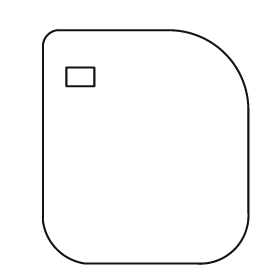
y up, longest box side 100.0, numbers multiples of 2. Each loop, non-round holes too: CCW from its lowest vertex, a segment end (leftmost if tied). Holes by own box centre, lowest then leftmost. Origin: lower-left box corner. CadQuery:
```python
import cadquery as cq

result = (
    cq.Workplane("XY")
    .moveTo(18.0, 0.0)
    .lineTo(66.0, 0.0)
    .threePointArc((82.0, 6.0), (88.0, 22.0))
    .lineTo(88.0, 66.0)
    .threePointArc((78.0, 90.0), (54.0, 100.0))
    .lineTo(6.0, 100.0)
    .threePointArc((2.0, 98.0), (0.0, 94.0))
    .lineTo(0.0, 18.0)
    .threePointArc((6.0, 6.0), (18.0, 0.0))
    .close()
    .moveTo(10.0, 76.0)
    .lineTo(22.0, 76.0)
    .lineTo(22.0, 84.0)
    .lineTo(10.0, 84.0)
    .close()
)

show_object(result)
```